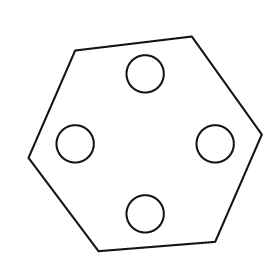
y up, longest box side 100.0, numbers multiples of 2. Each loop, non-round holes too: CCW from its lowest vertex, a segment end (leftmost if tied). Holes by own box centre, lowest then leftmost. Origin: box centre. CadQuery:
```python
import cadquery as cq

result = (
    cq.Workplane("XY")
    .moveTo(-20.0, -46.0)
    .lineTo(30.0, -42.0)
    .lineTo(50.0, 4.0)
    .lineTo(20.0, 46.0)
    .lineTo(-30.0, 40.0)
    .lineTo(-50.0, -6.0)
    .close()
    .moveTo(0.0, -30.0)
    .circle(8.0)
    .moveTo(-30.0, 0.0)
    .circle(8.0)
    .moveTo(30.0, 0.0)
    .circle(8.0)
    .moveTo(0.0, 30.0)
    .circle(8.0)
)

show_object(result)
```